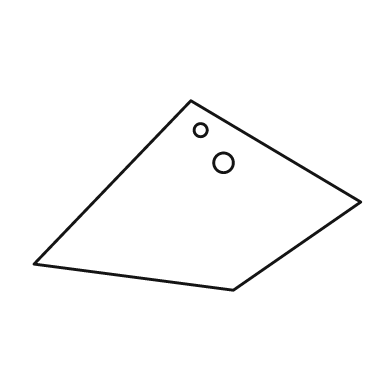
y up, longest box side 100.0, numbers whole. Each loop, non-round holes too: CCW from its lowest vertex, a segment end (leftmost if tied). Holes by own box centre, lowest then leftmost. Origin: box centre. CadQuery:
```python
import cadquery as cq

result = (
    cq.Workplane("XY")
    .moveTo(11.0, -29.0)
    .lineTo(50.0, -2.0)
    .lineTo(-2.0, 29.0)
    .lineTo(-50.0, -21.0)
    .close()
    .moveTo(8.0, 10.0)
    .circle(3.0)
    .moveTo(1.0, 20.0)
    .circle(2.0)
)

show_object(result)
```